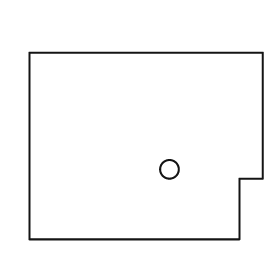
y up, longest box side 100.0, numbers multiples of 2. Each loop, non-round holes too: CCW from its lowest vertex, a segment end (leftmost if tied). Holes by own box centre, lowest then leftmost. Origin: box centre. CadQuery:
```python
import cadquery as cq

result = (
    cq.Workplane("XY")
    .moveTo(-50.0, -40.0)
    .lineTo(40.0, -40.0)
    .lineTo(40.0, -14.0)
    .lineTo(50.0, -14.0)
    .lineTo(50.0, 40.0)
    .lineTo(-50.0, 40.0)
    .close()
    .moveTo(10.0, -10.0)
    .circle(4.0)
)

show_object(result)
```